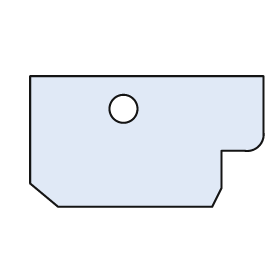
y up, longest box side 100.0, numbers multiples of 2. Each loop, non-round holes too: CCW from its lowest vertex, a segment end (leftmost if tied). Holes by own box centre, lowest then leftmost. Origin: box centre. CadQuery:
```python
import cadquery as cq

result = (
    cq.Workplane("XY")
    .moveTo(-38.0, -28.0)
    .lineTo(28.0, -28.0)
    .lineTo(32.0, -20.0)
    .lineTo(32.0, -4.0)
    .lineTo(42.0, -4.0)
    .threePointArc((48.0, -2.0), (50.0, 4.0))
    .lineTo(50.0, 28.0)
    .lineTo(-50.0, 28.0)
    .lineTo(-50.0, -18.0)
    .close()
    .moveTo(-10.0, 14.0)
    .circle(6.0)
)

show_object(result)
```